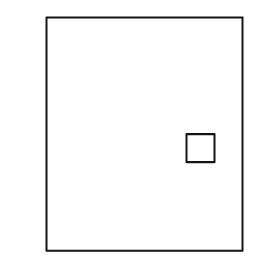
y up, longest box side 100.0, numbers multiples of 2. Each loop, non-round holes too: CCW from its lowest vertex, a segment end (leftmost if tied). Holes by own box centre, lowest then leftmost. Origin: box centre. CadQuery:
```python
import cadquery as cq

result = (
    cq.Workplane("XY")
    .moveTo(-42.0, -50.0)
    .lineTo(42.0, -50.0)
    .lineTo(42.0, 50.0)
    .lineTo(-42.0, 50.0)
    .close()
    .moveTo(18.0, -12.0)
    .lineTo(30.0, -12.0)
    .lineTo(30.0, 0.0)
    .lineTo(18.0, 0.0)
    .close()
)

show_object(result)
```